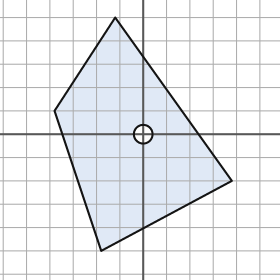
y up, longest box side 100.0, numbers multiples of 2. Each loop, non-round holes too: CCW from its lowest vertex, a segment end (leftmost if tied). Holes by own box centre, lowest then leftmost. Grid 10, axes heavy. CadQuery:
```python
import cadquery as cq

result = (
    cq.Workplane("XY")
    .moveTo(-18.0, -50.0)
    .lineTo(38.0, -20.0)
    .lineTo(-12.0, 50.0)
    .lineTo(-38.0, 10.0)
    .close()
    .moveTo(0.0, 0.0)
    .circle(4.0)
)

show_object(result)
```